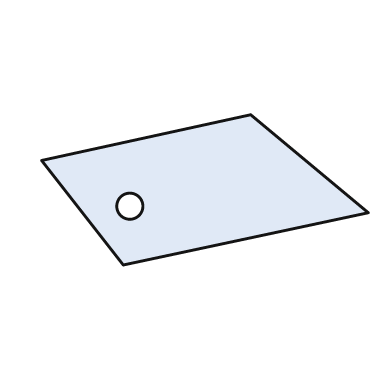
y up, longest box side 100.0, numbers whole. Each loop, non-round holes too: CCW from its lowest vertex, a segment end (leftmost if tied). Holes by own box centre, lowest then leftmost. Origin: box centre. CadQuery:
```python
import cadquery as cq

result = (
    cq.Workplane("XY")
    .moveTo(-25.0, -23.0)
    .lineTo(50.0, -7.0)
    .lineTo(14.0, 23.0)
    .lineTo(-50.0, 9.0)
    .close()
    .moveTo(-23.0, -5.0)
    .circle(4.0)
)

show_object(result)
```